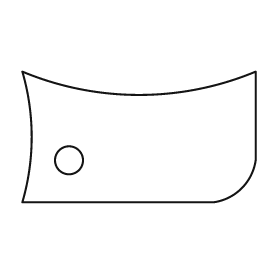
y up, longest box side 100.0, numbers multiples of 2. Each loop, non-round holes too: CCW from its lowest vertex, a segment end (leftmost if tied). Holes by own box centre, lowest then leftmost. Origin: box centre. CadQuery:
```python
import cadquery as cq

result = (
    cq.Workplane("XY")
    .moveTo(-50.0, -28.0)
    .lineTo(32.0, -28.0)
    .threePointArc((44.0, -22.0), (50.0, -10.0))
    .lineTo(50.0, 28.0)
    .threePointArc((0.0, 18.0), (-50.0, 28.0))
    .threePointArc((-46.0, 0.0), (-50.0, -28.0))
    .close()
    .moveTo(-30.0, -10.0)
    .circle(6.0)
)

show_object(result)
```